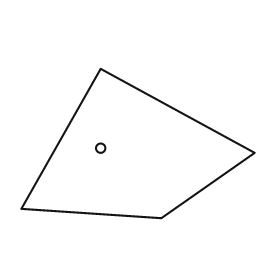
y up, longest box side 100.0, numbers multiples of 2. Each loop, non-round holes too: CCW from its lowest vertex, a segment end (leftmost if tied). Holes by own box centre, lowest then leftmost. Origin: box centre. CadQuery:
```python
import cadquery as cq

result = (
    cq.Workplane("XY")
    .moveTo(10.0, -32.0)
    .lineTo(50.0, -4.0)
    .lineTo(-16.0, 32.0)
    .lineTo(-50.0, -28.0)
    .close()
    .moveTo(-16.0, -2.0)
    .circle(2.0)
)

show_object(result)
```